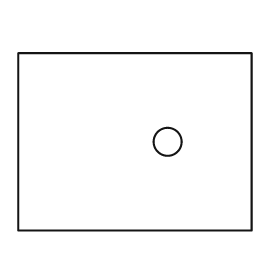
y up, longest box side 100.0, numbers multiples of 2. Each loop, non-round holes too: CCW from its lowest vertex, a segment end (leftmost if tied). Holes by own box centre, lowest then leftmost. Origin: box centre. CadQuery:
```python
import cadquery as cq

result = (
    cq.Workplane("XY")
    .moveTo(-50.0, -38.0)
    .lineTo(50.0, -38.0)
    .lineTo(50.0, 38.0)
    .lineTo(-50.0, 38.0)
    .close()
    .moveTo(14.0, 0.0)
    .circle(6.0)
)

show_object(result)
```